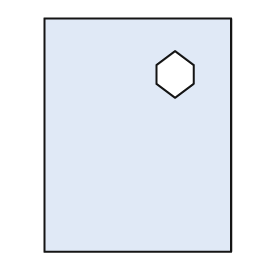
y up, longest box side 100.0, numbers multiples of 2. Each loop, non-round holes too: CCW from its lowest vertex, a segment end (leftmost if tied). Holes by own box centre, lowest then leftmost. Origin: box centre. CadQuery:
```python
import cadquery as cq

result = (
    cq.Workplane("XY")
    .moveTo(-40.0, -50.0)
    .lineTo(40.0, -50.0)
    .lineTo(40.0, 50.0)
    .lineTo(-40.0, 50.0)
    .close()
    .moveTo(16.0, 16.0)
    .lineTo(24.0, 22.0)
    .lineTo(24.0, 30.0)
    .lineTo(16.0, 36.0)
    .lineTo(8.0, 30.0)
    .lineTo(8.0, 22.0)
    .close()
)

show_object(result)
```